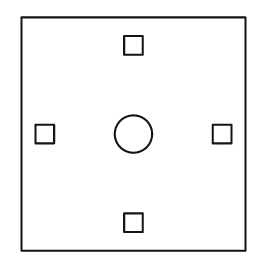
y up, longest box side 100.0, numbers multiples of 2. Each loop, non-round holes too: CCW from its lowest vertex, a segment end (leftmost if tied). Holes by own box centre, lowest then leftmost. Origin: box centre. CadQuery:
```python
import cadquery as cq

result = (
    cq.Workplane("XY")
    .moveTo(-48.0, -50.0)
    .lineTo(48.0, -50.0)
    .lineTo(48.0, 50.0)
    .lineTo(-48.0, 50.0)
    .close()
    .moveTo(-4.0, -42.0)
    .lineTo(4.0, -42.0)
    .lineTo(4.0, -34.0)
    .lineTo(-4.0, -34.0)
    .close()
    .moveTo(-42.0, -4.0)
    .lineTo(-34.0, -4.0)
    .lineTo(-34.0, 4.0)
    .lineTo(-42.0, 4.0)
    .close()
    .moveTo(0.0, 0.0)
    .circle(8.0)
    .moveTo(34.0, -4.0)
    .lineTo(42.0, -4.0)
    .lineTo(42.0, 4.0)
    .lineTo(34.0, 4.0)
    .close()
    .moveTo(-4.0, 34.0)
    .lineTo(4.0, 34.0)
    .lineTo(4.0, 42.0)
    .lineTo(-4.0, 42.0)
    .close()
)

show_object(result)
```